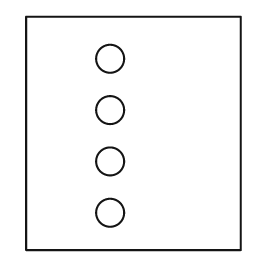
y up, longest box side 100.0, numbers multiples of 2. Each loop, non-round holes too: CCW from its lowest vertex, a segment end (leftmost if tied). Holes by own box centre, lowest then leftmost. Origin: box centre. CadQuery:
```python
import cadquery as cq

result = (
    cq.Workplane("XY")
    .moveTo(-46.0, -50.0)
    .lineTo(46.0, -50.0)
    .lineTo(46.0, 50.0)
    .lineTo(-46.0, 50.0)
    .close()
    .moveTo(-10.0, -34.0)
    .circle(6.0)
    .moveTo(-10.0, -12.0)
    .circle(6.0)
    .moveTo(-10.0, 10.0)
    .circle(6.0)
    .moveTo(-10.0, 32.0)
    .circle(6.0)
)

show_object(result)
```